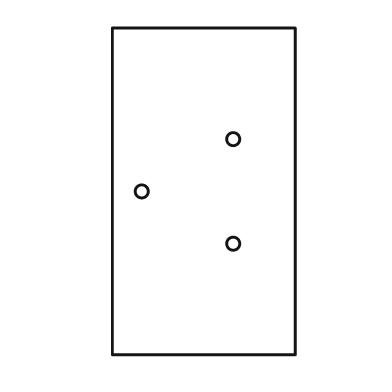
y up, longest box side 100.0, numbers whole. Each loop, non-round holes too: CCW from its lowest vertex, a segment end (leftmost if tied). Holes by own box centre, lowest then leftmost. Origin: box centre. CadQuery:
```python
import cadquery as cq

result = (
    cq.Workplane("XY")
    .moveTo(-28.0, -50.0)
    .lineTo(28.0, -50.0)
    .lineTo(28.0, 50.0)
    .lineTo(-28.0, 50.0)
    .close()
    .moveTo(9.0, -16.0)
    .circle(2.0)
    .moveTo(-19.0, 0.0)
    .circle(2.0)
    .moveTo(9.0, 16.0)
    .circle(2.0)
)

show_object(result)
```